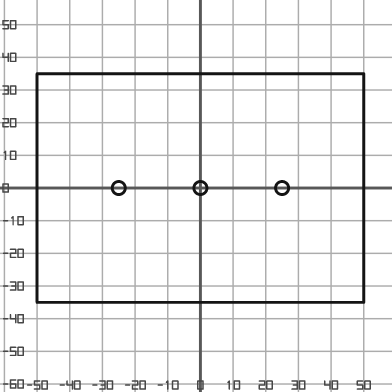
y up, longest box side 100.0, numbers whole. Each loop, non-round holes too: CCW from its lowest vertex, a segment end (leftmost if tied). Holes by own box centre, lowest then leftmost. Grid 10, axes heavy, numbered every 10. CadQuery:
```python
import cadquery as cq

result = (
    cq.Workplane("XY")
    .moveTo(-50.0, -35.0)
    .lineTo(50.0, -35.0)
    .lineTo(50.0, 35.0)
    .lineTo(-50.0, 35.0)
    .close()
    .moveTo(-25.0, 0.0)
    .circle(2.0)
    .moveTo(0.0, 0.0)
    .circle(2.0)
    .moveTo(25.0, 0.0)
    .circle(2.0)
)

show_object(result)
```